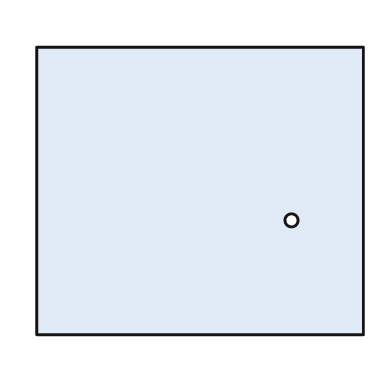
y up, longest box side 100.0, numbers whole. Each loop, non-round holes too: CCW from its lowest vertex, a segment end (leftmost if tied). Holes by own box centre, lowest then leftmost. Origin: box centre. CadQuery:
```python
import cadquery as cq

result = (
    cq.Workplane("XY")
    .moveTo(-50.0, -44.0)
    .lineTo(50.0, -44.0)
    .lineTo(50.0, 44.0)
    .lineTo(-50.0, 44.0)
    .close()
    .moveTo(28.0, -9.0)
    .circle(2.0)
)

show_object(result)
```